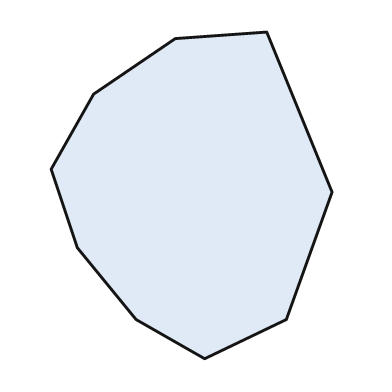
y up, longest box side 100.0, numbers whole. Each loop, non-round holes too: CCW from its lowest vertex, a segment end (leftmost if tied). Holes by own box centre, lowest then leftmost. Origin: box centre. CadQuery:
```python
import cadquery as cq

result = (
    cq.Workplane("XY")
    .moveTo(4.0, -50.0)
    .lineTo(29.0, -38.0)
    .lineTo(43.0, 1.0)
    .lineTo(23.0, 50.0)
    .lineTo(-5.0, 48.0)
    .lineTo(-30.0, 31.0)
    .lineTo(-43.0, 8.0)
    .lineTo(-35.0, -16.0)
    .lineTo(-17.0, -38.0)
    .close()
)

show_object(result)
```